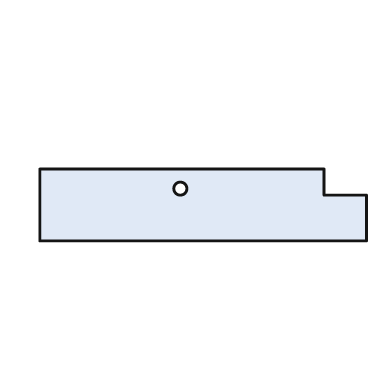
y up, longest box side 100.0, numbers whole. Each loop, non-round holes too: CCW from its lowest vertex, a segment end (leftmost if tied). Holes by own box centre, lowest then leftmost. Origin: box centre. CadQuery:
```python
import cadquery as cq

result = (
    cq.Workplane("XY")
    .moveTo(-50.0, -11.0)
    .lineTo(50.0, -11.0)
    .lineTo(50.0, 3.0)
    .lineTo(37.0, 3.0)
    .lineTo(37.0, 11.0)
    .lineTo(-50.0, 11.0)
    .close()
    .moveTo(-7.0, 5.0)
    .circle(2.0)
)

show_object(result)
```